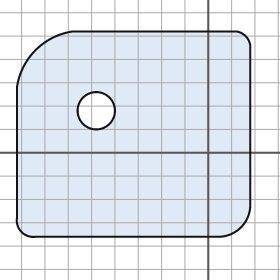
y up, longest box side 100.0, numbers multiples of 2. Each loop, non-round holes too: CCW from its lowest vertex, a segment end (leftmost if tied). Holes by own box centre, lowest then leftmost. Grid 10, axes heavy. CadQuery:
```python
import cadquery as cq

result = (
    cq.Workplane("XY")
    .moveTo(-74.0, -36.0)
    .lineTo(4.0, -36.0)
    .threePointArc((14.0, -32.0), (18.0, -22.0))
    .lineTo(18.0, 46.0)
    .threePointArc((16.0, 50.0), (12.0, 52.0))
    .lineTo(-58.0, 52.0)
    .threePointArc((-74.0, 44.0), (-82.0, 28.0))
    .lineTo(-82.0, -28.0)
    .threePointArc((-80.0, -34.0), (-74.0, -36.0))
    .close()
    .moveTo(-48.0, 18.0)
    .circle(8.0)
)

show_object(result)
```